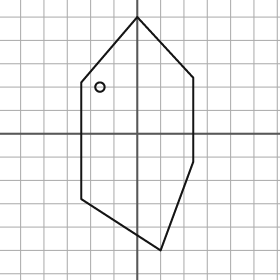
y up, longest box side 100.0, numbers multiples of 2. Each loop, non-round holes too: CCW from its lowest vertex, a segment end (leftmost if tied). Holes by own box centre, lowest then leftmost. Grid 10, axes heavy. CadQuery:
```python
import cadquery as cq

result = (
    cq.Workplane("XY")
    .moveTo(10.0, -50.0)
    .lineTo(24.0, -12.0)
    .lineTo(24.0, 24.0)
    .lineTo(0.0, 50.0)
    .lineTo(-24.0, 22.0)
    .lineTo(-24.0, -28.0)
    .close()
    .moveTo(-16.0, 20.0)
    .circle(2.0)
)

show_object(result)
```